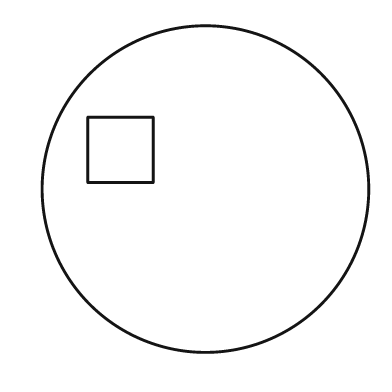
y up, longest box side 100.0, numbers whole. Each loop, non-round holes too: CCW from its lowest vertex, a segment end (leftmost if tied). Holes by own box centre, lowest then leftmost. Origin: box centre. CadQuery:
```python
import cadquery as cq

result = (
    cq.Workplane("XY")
    .moveTo(0.0, 0.0)
    .circle(50.0)
    .moveTo(-36.0, 2.0)
    .lineTo(-16.0, 2.0)
    .lineTo(-16.0, 22.0)
    .lineTo(-36.0, 22.0)
    .close()
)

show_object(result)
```